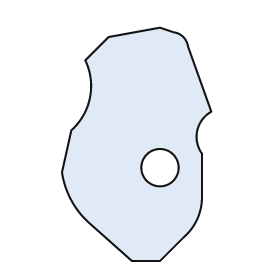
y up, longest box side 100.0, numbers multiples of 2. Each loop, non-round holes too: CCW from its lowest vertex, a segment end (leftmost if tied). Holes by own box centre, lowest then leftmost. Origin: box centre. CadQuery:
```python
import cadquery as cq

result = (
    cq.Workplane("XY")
    .moveTo(-2.0, -50.0)
    .lineTo(10.0, -50.0)
    .lineTo(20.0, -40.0)
    .threePointArc((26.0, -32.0), (28.0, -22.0))
    .lineTo(28.0, -4.0)
    .threePointArc((26.0, 6.0), (32.0, 14.0))
    .lineTo(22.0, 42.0)
    .threePointArc((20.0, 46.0), (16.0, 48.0))
    .lineTo(10.0, 50.0)
    .lineTo(-12.0, 46.0)
    .lineTo(-22.0, 36.0)
    .threePointArc((-20.0, 20.0), (-28.0, 6.0))
    .lineTo(-32.0, -12.0)
    .threePointArc((-28.0, -24.0), (-20.0, -34.0))
    .close()
    .moveTo(10.0, -10.0)
    .circle(8.0)
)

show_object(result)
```